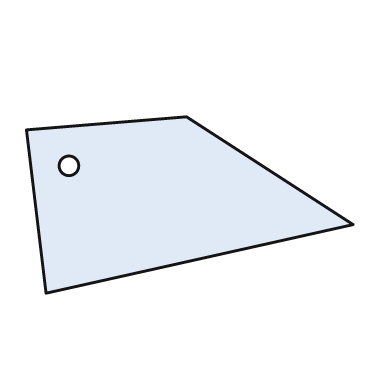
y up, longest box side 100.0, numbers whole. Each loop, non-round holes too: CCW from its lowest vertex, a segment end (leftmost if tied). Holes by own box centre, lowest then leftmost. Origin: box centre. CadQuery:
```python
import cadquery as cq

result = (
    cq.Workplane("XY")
    .moveTo(-44.0, -27.0)
    .lineTo(50.0, -6.0)
    .lineTo(-1.0, 27.0)
    .lineTo(-50.0, 23.0)
    .close()
    .moveTo(-37.0, 12.0)
    .circle(3.0)
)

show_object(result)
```